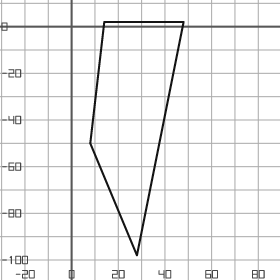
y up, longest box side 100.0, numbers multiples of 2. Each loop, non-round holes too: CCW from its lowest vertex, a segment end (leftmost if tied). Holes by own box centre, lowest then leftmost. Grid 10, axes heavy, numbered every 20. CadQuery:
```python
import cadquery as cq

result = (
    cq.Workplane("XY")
    .moveTo(28.0, -98.0)
    .lineTo(48.0, 2.0)
    .lineTo(14.0, 2.0)
    .lineTo(8.0, -50.0)
    .close()
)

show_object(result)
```